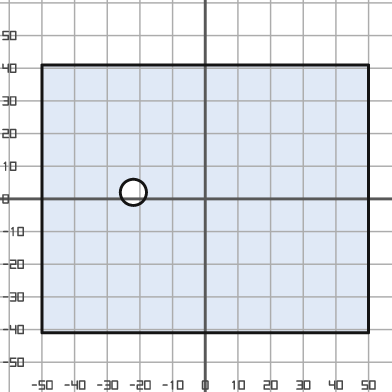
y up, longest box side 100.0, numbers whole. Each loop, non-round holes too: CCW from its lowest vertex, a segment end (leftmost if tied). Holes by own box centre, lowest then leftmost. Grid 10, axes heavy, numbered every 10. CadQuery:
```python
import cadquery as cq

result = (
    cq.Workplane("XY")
    .moveTo(-50.0, -41.0)
    .lineTo(50.0, -41.0)
    .lineTo(50.0, 41.0)
    .lineTo(-50.0, 41.0)
    .close()
    .moveTo(-22.0, 2.0)
    .circle(4.0)
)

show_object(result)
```